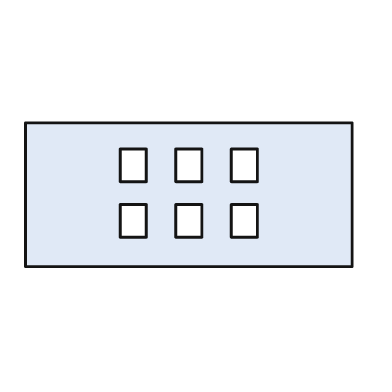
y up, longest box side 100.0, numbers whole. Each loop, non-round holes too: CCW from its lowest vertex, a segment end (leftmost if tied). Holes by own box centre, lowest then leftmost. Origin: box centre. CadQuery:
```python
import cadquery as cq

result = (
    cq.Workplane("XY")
    .moveTo(-50.0, -22.0)
    .lineTo(50.0, -22.0)
    .lineTo(50.0, 22.0)
    .lineTo(-50.0, 22.0)
    .close()
    .moveTo(-21.0, -13.0)
    .lineTo(-13.0, -13.0)
    .lineTo(-13.0, -3.0)
    .lineTo(-21.0, -3.0)
    .close()
    .moveTo(-4.0, -13.0)
    .lineTo(4.0, -13.0)
    .lineTo(4.0, -3.0)
    .lineTo(-4.0, -3.0)
    .close()
    .moveTo(13.0, -13.0)
    .lineTo(21.0, -13.0)
    .lineTo(21.0, -3.0)
    .lineTo(13.0, -3.0)
    .close()
    .moveTo(-21.0, 4.0)
    .lineTo(-13.0, 4.0)
    .lineTo(-13.0, 14.0)
    .lineTo(-21.0, 14.0)
    .close()
    .moveTo(-4.0, 4.0)
    .lineTo(4.0, 4.0)
    .lineTo(4.0, 14.0)
    .lineTo(-4.0, 14.0)
    .close()
    .moveTo(13.0, 4.0)
    .lineTo(21.0, 4.0)
    .lineTo(21.0, 14.0)
    .lineTo(13.0, 14.0)
    .close()
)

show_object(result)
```